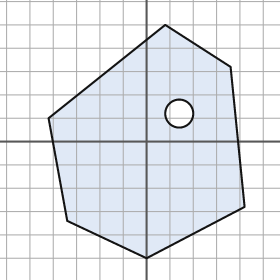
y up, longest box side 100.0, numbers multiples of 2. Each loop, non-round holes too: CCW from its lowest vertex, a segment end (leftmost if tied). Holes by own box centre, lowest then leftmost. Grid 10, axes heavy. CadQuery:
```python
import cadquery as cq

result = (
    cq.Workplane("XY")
    .moveTo(0.0, -50.0)
    .lineTo(42.0, -28.0)
    .lineTo(36.0, 32.0)
    .lineTo(8.0, 50.0)
    .lineTo(-42.0, 10.0)
    .lineTo(-34.0, -34.0)
    .close()
    .moveTo(14.0, 12.0)
    .circle(6.0)
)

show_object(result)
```